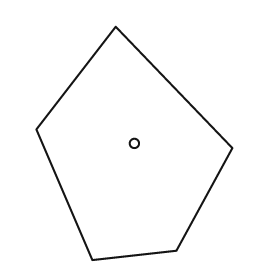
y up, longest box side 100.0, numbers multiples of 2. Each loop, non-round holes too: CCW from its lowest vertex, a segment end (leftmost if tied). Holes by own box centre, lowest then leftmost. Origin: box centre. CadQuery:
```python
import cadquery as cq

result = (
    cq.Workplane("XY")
    .moveTo(-18.0, -50.0)
    .lineTo(18.0, -46.0)
    .lineTo(42.0, -2.0)
    .lineTo(-8.0, 50.0)
    .lineTo(-42.0, 6.0)
    .close()
    .moveTo(0.0, 0.0)
    .circle(2.0)
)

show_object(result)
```